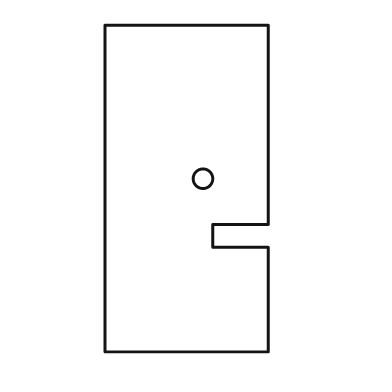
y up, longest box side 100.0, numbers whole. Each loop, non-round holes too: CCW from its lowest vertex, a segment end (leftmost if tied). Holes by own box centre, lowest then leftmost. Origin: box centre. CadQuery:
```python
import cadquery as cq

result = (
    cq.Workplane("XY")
    .moveTo(-25.0, -50.0)
    .lineTo(25.0, -50.0)
    .lineTo(25.0, -18.0)
    .lineTo(8.0, -18.0)
    .lineTo(8.0, -11.0)
    .lineTo(25.0, -11.0)
    .lineTo(25.0, 50.0)
    .lineTo(-25.0, 50.0)
    .close()
    .moveTo(5.0, 3.0)
    .circle(3.0)
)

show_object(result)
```